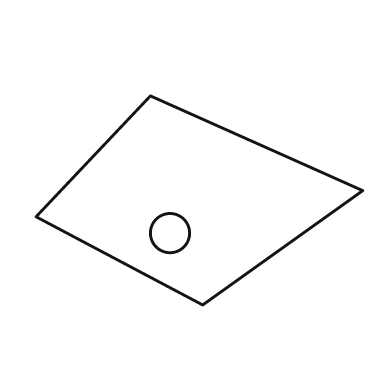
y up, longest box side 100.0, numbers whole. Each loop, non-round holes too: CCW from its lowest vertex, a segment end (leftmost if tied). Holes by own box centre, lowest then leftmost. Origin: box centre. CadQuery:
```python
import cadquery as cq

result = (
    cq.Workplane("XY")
    .moveTo(1.0, -32.0)
    .lineTo(50.0, 3.0)
    .lineTo(-15.0, 32.0)
    .lineTo(-50.0, -5.0)
    .close()
    .moveTo(-9.0, -10.0)
    .circle(6.0)
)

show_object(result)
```